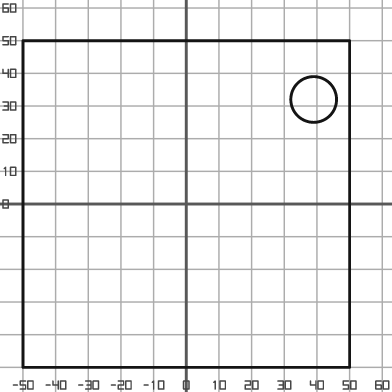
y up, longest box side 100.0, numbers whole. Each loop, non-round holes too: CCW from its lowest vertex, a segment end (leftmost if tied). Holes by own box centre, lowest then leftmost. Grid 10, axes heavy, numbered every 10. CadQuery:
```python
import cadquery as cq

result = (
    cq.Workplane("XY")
    .moveTo(-50.0, -50.0)
    .lineTo(50.0, -50.0)
    .lineTo(50.0, 50.0)
    .lineTo(-50.0, 50.0)
    .close()
    .moveTo(39.0, 32.0)
    .circle(7.0)
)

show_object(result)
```